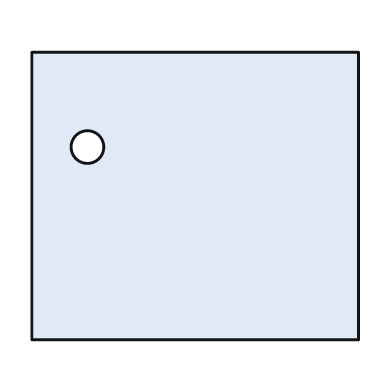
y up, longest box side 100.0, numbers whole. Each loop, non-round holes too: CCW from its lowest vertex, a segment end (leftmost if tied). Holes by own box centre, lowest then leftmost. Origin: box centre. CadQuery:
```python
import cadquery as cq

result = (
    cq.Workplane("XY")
    .moveTo(-50.0, -44.0)
    .lineTo(50.0, -44.0)
    .lineTo(50.0, 44.0)
    .lineTo(-50.0, 44.0)
    .close()
    .moveTo(-33.0, 15.0)
    .circle(5.0)
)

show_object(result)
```